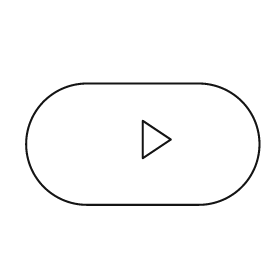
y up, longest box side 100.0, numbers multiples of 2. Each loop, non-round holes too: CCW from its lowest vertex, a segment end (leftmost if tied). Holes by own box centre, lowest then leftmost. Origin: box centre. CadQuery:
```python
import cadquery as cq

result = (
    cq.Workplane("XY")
    .moveTo(-24.0, -26.0)
    .lineTo(24.0, -26.0)
    .threePointArc((50.0, 0.0), (24.0, 26.0))
    .lineTo(-24.0, 26.0)
    .threePointArc((-50.0, 0.0), (-24.0, -26.0))
    .close()
    .moveTo(0.0, -6.0)
    .lineTo(12.0, 2.0)
    .lineTo(0.0, 10.0)
    .close()
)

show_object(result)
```